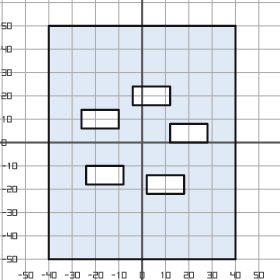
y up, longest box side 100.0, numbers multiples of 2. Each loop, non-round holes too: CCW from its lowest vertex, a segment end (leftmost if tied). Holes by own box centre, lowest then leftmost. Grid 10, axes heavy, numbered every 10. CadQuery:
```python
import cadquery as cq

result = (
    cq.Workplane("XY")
    .moveTo(-40.0, -50.0)
    .lineTo(40.0, -50.0)
    .lineTo(40.0, 50.0)
    .lineTo(-40.0, 50.0)
    .close()
    .moveTo(2.0, -22.0)
    .lineTo(18.0, -22.0)
    .lineTo(18.0, -14.0)
    .lineTo(2.0, -14.0)
    .close()
    .moveTo(-24.0, -18.0)
    .lineTo(-8.0, -18.0)
    .lineTo(-8.0, -10.0)
    .lineTo(-24.0, -10.0)
    .close()
    .moveTo(12.0, 0.0)
    .lineTo(28.0, 0.0)
    .lineTo(28.0, 8.0)
    .lineTo(12.0, 8.0)
    .close()
    .moveTo(-26.0, 6.0)
    .lineTo(-10.0, 6.0)
    .lineTo(-10.0, 14.0)
    .lineTo(-26.0, 14.0)
    .close()
    .moveTo(-4.0, 16.0)
    .lineTo(12.0, 16.0)
    .lineTo(12.0, 24.0)
    .lineTo(-4.0, 24.0)
    .close()
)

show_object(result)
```